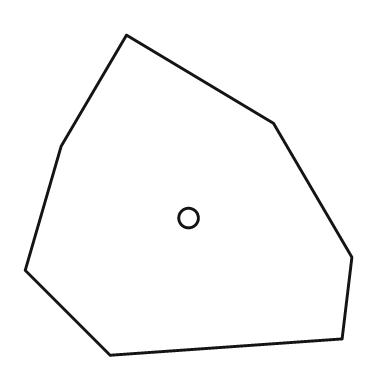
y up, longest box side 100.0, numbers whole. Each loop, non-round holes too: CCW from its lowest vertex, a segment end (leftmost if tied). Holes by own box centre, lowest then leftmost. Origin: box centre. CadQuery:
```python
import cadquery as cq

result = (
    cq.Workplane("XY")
    .moveTo(-24.0, -49.0)
    .lineTo(47.0, -44.0)
    .lineTo(50.0, -19.0)
    .lineTo(26.0, 22.0)
    .lineTo(-19.0, 49.0)
    .lineTo(-39.0, 15.0)
    .lineTo(-50.0, -23.0)
    .close()
    .moveTo(0.0, -7.0)
    .circle(3.0)
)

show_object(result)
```